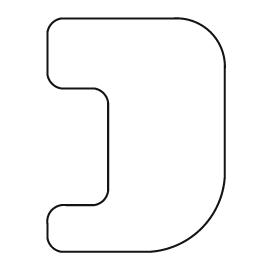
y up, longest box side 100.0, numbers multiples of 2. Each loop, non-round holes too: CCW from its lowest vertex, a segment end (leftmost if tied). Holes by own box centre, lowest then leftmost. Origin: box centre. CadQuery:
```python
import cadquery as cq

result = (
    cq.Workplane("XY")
    .moveTo(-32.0, -50.0)
    .lineTo(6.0, -50.0)
    .threePointArc((28.0, -40.0), (38.0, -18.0))
    .lineTo(38.0, 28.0)
    .threePointArc((32.0, 44.0), (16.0, 50.0))
    .lineTo(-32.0, 50.0)
    .threePointArc((-36.0, 48.0), (-38.0, 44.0))
    .lineTo(-38.0, 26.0)
    .threePointArc((-36.0, 22.0), (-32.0, 20.0))
    .lineTo(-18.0, 20.0)
    .threePointArc((-14.0, 18.0), (-12.0, 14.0))
    .lineTo(-12.0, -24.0)
    .threePointArc((-14.0, -28.0), (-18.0, -30.0))
    .lineTo(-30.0, -30.0)
    .threePointArc((-36.0, -32.0), (-38.0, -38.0))
    .lineTo(-38.0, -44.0)
    .threePointArc((-36.0, -48.0), (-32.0, -50.0))
    .close()
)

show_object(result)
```